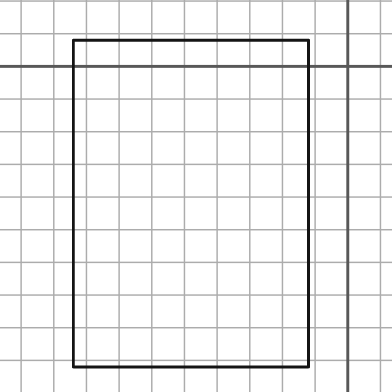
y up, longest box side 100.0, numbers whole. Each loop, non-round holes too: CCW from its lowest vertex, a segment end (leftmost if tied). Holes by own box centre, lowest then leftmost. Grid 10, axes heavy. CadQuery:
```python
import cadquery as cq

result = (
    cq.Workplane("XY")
    .moveTo(-84.0, -92.0)
    .lineTo(-12.0, -92.0)
    .lineTo(-12.0, 8.0)
    .lineTo(-84.0, 8.0)
    .close()
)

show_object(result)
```